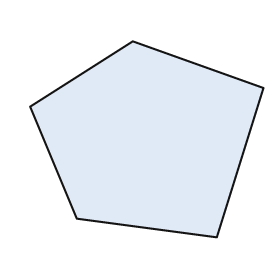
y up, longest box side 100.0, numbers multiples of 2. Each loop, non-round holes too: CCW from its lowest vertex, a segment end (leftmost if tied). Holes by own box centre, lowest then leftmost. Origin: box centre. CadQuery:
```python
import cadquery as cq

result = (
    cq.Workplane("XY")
    .moveTo(30.0, -42.0)
    .lineTo(50.0, 22.0)
    .lineTo(-6.0, 42.0)
    .lineTo(-50.0, 14.0)
    .lineTo(-30.0, -34.0)
    .close()
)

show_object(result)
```